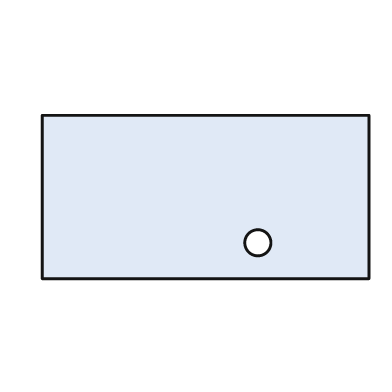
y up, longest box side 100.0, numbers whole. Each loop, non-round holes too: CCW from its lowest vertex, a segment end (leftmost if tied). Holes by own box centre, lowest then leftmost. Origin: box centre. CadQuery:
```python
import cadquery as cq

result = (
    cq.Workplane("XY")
    .moveTo(-50.0, -25.0)
    .lineTo(50.0, -25.0)
    .lineTo(50.0, 25.0)
    .lineTo(-50.0, 25.0)
    .close()
    .moveTo(16.0, -14.0)
    .circle(4.0)
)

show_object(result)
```